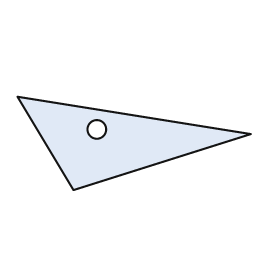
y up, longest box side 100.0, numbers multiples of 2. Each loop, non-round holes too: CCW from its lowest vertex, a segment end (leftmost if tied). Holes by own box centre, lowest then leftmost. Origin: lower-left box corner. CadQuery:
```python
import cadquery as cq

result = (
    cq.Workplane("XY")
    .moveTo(24.0, 0.0)
    .lineTo(100.0, 24.0)
    .lineTo(0.0, 40.0)
    .close()
    .moveTo(34.0, 26.0)
    .circle(4.0)
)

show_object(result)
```